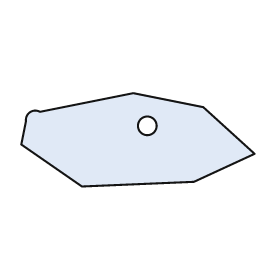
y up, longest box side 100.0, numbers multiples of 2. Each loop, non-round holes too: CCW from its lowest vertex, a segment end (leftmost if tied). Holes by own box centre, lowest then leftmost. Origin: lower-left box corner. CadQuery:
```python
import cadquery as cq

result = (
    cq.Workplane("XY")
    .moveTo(26.0, 0.0)
    .lineTo(74.0, 2.0)
    .lineTo(100.0, 14.0)
    .lineTo(78.0, 34.0)
    .lineTo(48.0, 40.0)
    .lineTo(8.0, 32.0)
    .threePointArc((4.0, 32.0), (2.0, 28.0))
    .lineTo(0.0, 18.0)
    .close()
    .moveTo(54.0, 26.0)
    .circle(4.0)
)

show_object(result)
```